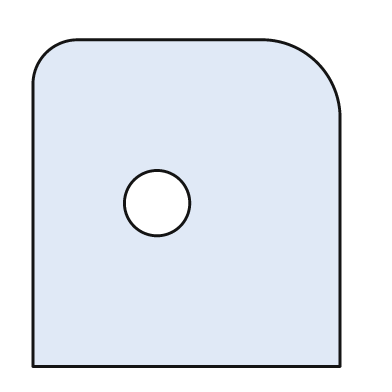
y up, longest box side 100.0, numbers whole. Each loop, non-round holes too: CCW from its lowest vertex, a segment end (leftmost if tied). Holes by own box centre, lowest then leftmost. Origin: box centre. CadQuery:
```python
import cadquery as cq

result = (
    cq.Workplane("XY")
    .moveTo(-47.0, -50.0)
    .lineTo(47.0, -50.0)
    .lineTo(47.0, 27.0)
    .threePointArc((40.0, 43.0), (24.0, 50.0))
    .lineTo(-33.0, 50.0)
    .threePointArc((-43.0, 46.0), (-47.0, 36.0))
    .close()
    .moveTo(-9.0, 0.0)
    .circle(10.0)
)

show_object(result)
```